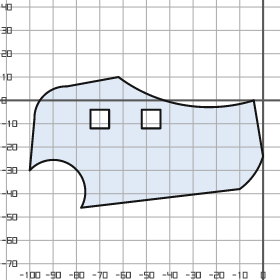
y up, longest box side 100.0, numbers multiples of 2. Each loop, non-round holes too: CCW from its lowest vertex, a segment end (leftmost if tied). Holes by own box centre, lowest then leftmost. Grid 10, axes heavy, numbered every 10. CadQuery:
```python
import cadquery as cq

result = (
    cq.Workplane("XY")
    .moveTo(-78.0, -46.0)
    .lineTo(-10.0, -38.0)
    .threePointArc((-4.0, -32.0), (0.0, -24.0))
    .lineTo(-4.0, 0.0)
    .threePointArc((-34.0, -2.0), (-62.0, 10.0))
    .lineTo(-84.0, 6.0)
    .threePointArc((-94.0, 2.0), (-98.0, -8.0))
    .lineTo(-100.0, -30.0)
    .threePointArc((-82.0, -28.0), (-78.0, -46.0))
    .close()
    .moveTo(-74.0, -12.0)
    .lineTo(-66.0, -12.0)
    .lineTo(-66.0, -4.0)
    .lineTo(-74.0, -4.0)
    .close()
    .moveTo(-52.0, -12.0)
    .lineTo(-44.0, -12.0)
    .lineTo(-44.0, -4.0)
    .lineTo(-52.0, -4.0)
    .close()
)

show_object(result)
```